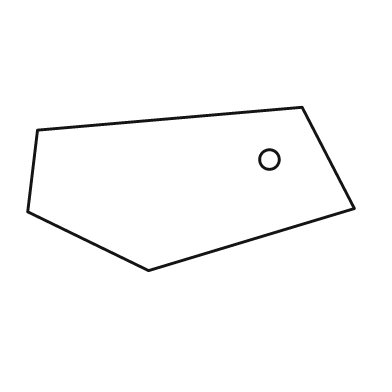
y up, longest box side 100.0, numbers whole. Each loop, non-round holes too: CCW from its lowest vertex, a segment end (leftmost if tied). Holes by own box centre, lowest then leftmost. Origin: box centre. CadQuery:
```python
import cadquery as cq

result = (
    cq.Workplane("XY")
    .moveTo(-13.0, -25.0)
    .lineTo(50.0, -6.0)
    .lineTo(34.0, 25.0)
    .lineTo(-47.0, 18.0)
    .lineTo(-50.0, -7.0)
    .close()
    .moveTo(24.0, 9.0)
    .circle(3.0)
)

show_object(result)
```